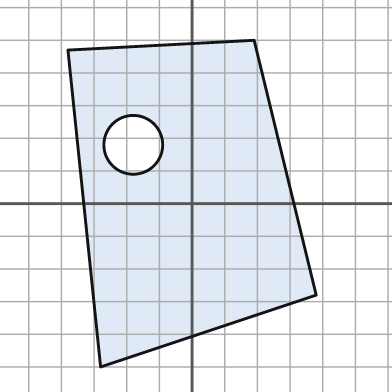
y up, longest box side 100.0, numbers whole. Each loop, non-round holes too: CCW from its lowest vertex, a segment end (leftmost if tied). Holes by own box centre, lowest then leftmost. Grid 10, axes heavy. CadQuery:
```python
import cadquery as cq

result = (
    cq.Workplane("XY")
    .moveTo(-28.0, -50.0)
    .lineTo(38.0, -28.0)
    .lineTo(19.0, 50.0)
    .lineTo(-38.0, 47.0)
    .close()
    .moveTo(-18.0, 18.0)
    .circle(9.0)
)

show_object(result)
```